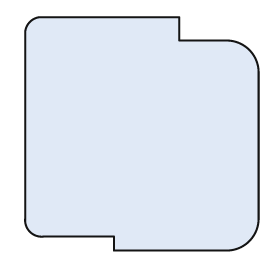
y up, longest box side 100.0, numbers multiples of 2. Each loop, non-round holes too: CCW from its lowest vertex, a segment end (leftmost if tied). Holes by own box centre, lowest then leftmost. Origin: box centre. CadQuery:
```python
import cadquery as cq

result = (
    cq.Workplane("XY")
    .moveTo(-12.0, -50.0)
    .lineTo(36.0, -50.0)
    .threePointArc((46.0, -46.0), (50.0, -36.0))
    .lineTo(50.0, 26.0)
    .threePointArc((46.0, 36.0), (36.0, 40.0))
    .lineTo(16.0, 40.0)
    .lineTo(16.0, 50.0)
    .lineTo(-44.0, 50.0)
    .threePointArc((-48.0, 48.0), (-50.0, 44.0))
    .lineTo(-50.0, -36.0)
    .threePointArc((-48.0, -42.0), (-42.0, -44.0))
    .lineTo(-12.0, -44.0)
    .close()
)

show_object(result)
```